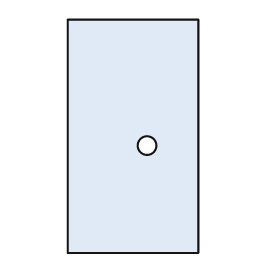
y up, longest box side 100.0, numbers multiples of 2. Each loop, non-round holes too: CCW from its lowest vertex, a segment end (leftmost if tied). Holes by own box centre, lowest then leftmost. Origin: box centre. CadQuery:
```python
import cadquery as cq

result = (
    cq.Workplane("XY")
    .moveTo(-28.0, -50.0)
    .lineTo(28.0, -50.0)
    .lineTo(28.0, 50.0)
    .lineTo(-28.0, 50.0)
    .close()
    .moveTo(6.0, -4.0)
    .circle(4.0)
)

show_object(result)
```